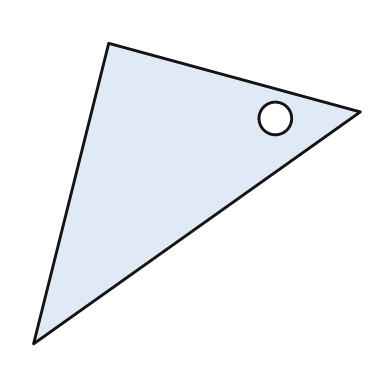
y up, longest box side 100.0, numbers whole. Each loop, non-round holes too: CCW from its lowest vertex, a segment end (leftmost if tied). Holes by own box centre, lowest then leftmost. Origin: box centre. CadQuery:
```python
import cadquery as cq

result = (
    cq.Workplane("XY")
    .moveTo(-50.0, -46.0)
    .lineTo(50.0, 25.0)
    .lineTo(-27.0, 46.0)
    .close()
    .moveTo(24.0, 23.0)
    .circle(5.0)
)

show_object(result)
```